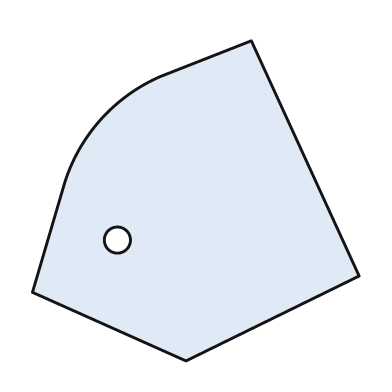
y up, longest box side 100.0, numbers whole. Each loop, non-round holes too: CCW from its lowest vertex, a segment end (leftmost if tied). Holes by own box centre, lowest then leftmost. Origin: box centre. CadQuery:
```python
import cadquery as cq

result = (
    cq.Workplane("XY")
    .moveTo(-3.0, -49.0)
    .lineTo(50.0, -23.0)
    .lineTo(17.0, 49.0)
    .lineTo(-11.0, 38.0)
    .threePointArc((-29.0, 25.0), (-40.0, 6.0))
    .lineTo(-50.0, -28.0)
    .close()
    .moveTo(-24.0, -12.0)
    .circle(4.0)
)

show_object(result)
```